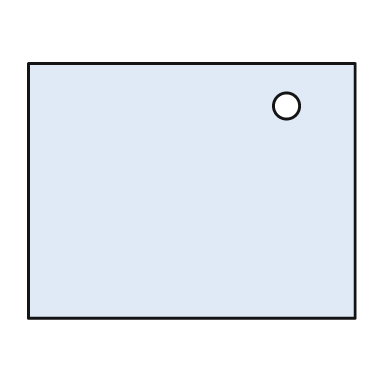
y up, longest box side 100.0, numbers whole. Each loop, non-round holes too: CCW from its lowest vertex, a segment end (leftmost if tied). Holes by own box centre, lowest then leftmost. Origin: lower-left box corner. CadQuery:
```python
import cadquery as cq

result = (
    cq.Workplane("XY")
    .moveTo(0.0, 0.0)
    .lineTo(100.0, 0.0)
    .lineTo(100.0, 78.0)
    .lineTo(0.0, 78.0)
    .close()
    .moveTo(79.0, 65.0)
    .circle(4.0)
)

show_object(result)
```